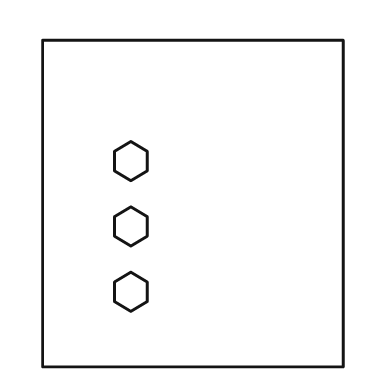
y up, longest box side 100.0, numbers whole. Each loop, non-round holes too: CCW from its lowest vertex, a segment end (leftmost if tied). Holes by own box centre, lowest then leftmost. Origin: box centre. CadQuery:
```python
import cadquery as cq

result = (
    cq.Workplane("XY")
    .moveTo(-46.0, -50.0)
    .lineTo(46.0, -50.0)
    .lineTo(46.0, 50.0)
    .lineTo(-46.0, 50.0)
    .close()
    .moveTo(-19.0, -33.0)
    .lineTo(-14.0, -30.0)
    .lineTo(-14.0, -24.0)
    .lineTo(-19.0, -21.0)
    .lineTo(-24.0, -24.0)
    .lineTo(-24.0, -30.0)
    .close()
    .moveTo(-19.0, -13.0)
    .lineTo(-14.0, -10.0)
    .lineTo(-14.0, -4.0)
    .lineTo(-19.0, -1.0)
    .lineTo(-24.0, -4.0)
    .lineTo(-24.0, -10.0)
    .close()
    .moveTo(-19.0, 7.0)
    .lineTo(-14.0, 10.0)
    .lineTo(-14.0, 16.0)
    .lineTo(-19.0, 19.0)
    .lineTo(-24.0, 16.0)
    .lineTo(-24.0, 10.0)
    .close()
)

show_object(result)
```